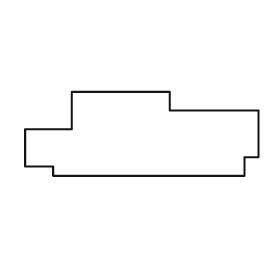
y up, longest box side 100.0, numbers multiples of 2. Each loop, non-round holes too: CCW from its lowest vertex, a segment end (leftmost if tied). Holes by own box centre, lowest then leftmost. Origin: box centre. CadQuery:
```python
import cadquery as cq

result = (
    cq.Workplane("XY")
    .moveTo(-38.0, -18.0)
    .lineTo(44.0, -18.0)
    .lineTo(44.0, -10.0)
    .lineTo(50.0, -10.0)
    .lineTo(50.0, 10.0)
    .lineTo(12.0, 10.0)
    .lineTo(12.0, 18.0)
    .lineTo(-30.0, 18.0)
    .lineTo(-30.0, 2.0)
    .lineTo(-50.0, 2.0)
    .lineTo(-50.0, -14.0)
    .lineTo(-38.0, -14.0)
    .close()
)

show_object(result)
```